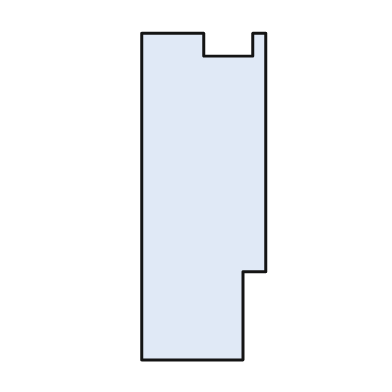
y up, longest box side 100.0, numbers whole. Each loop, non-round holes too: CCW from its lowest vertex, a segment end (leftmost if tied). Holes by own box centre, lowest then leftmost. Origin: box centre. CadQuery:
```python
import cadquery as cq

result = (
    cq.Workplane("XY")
    .moveTo(-19.0, -50.0)
    .lineTo(12.0, -50.0)
    .lineTo(12.0, -23.0)
    .lineTo(19.0, -23.0)
    .lineTo(19.0, 50.0)
    .lineTo(15.0, 50.0)
    .lineTo(15.0, 43.0)
    .lineTo(0.0, 43.0)
    .lineTo(0.0, 50.0)
    .lineTo(-19.0, 50.0)
    .close()
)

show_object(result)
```